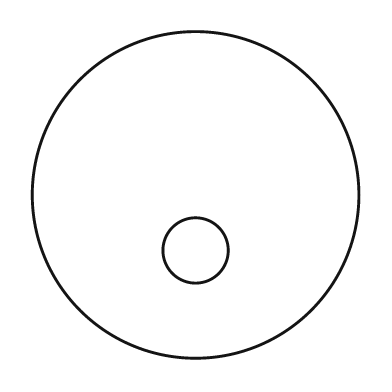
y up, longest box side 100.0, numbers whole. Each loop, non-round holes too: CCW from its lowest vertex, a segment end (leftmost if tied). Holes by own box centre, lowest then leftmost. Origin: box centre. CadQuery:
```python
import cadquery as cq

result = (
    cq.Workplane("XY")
    .moveTo(0.0, 0.0)
    .circle(50.0)
    .moveTo(0.0, -17.0)
    .circle(10.0)
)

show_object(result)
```